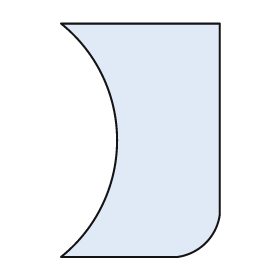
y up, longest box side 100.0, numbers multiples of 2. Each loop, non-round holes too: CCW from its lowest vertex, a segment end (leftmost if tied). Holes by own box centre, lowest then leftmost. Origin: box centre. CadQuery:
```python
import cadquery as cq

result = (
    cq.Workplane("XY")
    .moveTo(-34.0, -50.0)
    .lineTo(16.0, -50.0)
    .threePointArc((28.0, -44.0), (34.0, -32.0))
    .lineTo(34.0, 50.0)
    .lineTo(-34.0, 50.0)
    .threePointArc((-10.0, 0.0), (-34.0, -50.0))
    .close()
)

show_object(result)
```